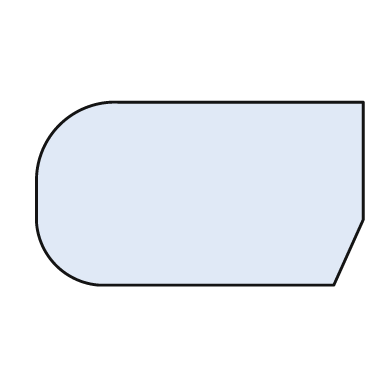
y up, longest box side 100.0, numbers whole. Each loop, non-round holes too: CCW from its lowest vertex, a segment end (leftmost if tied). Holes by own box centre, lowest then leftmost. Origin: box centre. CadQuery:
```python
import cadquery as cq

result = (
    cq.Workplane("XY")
    .moveTo(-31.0, -28.0)
    .lineTo(41.0, -28.0)
    .lineTo(50.0, -8.0)
    .lineTo(50.0, 28.0)
    .lineTo(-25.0, 28.0)
    .threePointArc((-43.0, 21.0), (-50.0, 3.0))
    .lineTo(-50.0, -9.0)
    .threePointArc((-44.0, -22.0), (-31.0, -28.0))
    .close()
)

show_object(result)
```